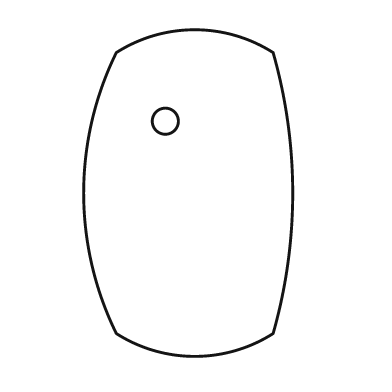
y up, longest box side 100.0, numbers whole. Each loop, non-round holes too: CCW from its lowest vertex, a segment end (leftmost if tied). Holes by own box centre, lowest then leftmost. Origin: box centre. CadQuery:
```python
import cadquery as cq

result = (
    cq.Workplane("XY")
    .moveTo(-22.0, -43.0)
    .threePointArc((2.0, -50.0), (26.0, -43.0))
    .threePointArc((32.0, 0.0), (26.0, 43.0))
    .threePointArc((2.0, 50.0), (-22.0, 43.0))
    .threePointArc((-32.0, 0.0), (-22.0, -43.0))
    .close()
    .moveTo(-7.0, 22.0)
    .circle(4.0)
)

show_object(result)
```